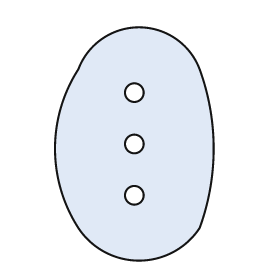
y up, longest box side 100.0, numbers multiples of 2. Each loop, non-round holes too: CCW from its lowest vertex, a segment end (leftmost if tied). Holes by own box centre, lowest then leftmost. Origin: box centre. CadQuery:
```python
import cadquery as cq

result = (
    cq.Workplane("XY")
    .moveTo(-24.0, -36.0)
    .threePointArc((2.0, -50.0), (28.0, -36.0))
    .threePointArc((34.0, -2.0), (28.0, 32.0))
    .threePointArc((2.0, 50.0), (-24.0, 32.0))
    .threePointArc((-34.0, -2.0), (-24.0, -36.0))
    .close()
    .moveTo(0.0, -22.0)
    .circle(4.0)
    .moveTo(0.0, 0.0)
    .circle(4.0)
    .moveTo(0.0, 22.0)
    .circle(4.0)
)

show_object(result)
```